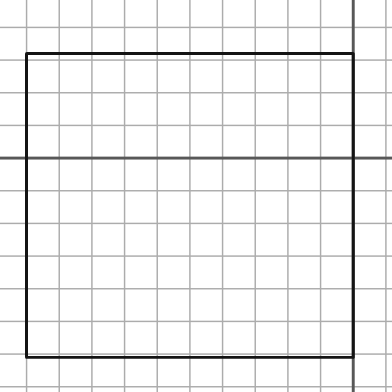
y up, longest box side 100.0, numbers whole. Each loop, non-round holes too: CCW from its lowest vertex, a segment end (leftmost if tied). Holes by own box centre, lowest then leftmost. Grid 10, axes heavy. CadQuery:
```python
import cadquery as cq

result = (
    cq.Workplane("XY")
    .moveTo(-100.0, -61.0)
    .lineTo(0.0, -61.0)
    .lineTo(0.0, 32.0)
    .lineTo(-100.0, 32.0)
    .close()
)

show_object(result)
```